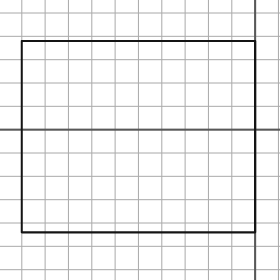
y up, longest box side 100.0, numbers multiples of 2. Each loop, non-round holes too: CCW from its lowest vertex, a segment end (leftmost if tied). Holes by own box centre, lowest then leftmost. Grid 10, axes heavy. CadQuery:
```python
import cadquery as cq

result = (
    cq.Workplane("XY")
    .moveTo(-100.0, -44.0)
    .lineTo(0.0, -44.0)
    .lineTo(0.0, 38.0)
    .lineTo(-100.0, 38.0)
    .close()
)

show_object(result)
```